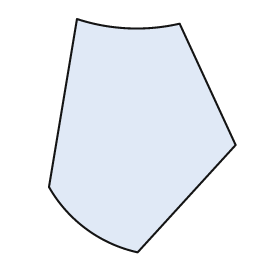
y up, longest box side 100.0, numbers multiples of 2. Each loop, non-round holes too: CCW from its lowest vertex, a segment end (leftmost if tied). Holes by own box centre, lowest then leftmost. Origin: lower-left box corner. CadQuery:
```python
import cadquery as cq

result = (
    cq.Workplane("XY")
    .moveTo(38.0, 0.0)
    .lineTo(80.0, 46.0)
    .lineTo(56.0, 98.0)
    .threePointArc((34.0, 96.0), (12.0, 100.0))
    .lineTo(0.0, 28.0)
    .threePointArc((16.0, 10.0), (38.0, 0.0))
    .close()
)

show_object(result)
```